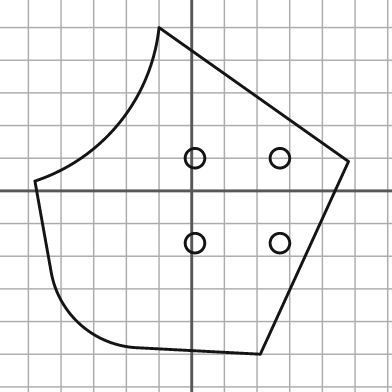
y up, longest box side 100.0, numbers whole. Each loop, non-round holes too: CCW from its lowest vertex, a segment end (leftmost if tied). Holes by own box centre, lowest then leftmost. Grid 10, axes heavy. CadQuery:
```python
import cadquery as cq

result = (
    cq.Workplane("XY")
    .moveTo(21.0, -50.0)
    .lineTo(48.0, 9.0)
    .lineTo(-10.0, 50.0)
    .threePointArc((-22.0, 21.0), (-48.0, 3.0))
    .lineTo(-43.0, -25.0)
    .threePointArc((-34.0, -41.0), (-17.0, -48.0))
    .close()
    .moveTo(1.0, -16.0)
    .circle(3.0)
    .moveTo(27.0, -16.0)
    .circle(3.0)
    .moveTo(1.0, 10.0)
    .circle(3.0)
    .moveTo(27.0, 10.0)
    .circle(3.0)
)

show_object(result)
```